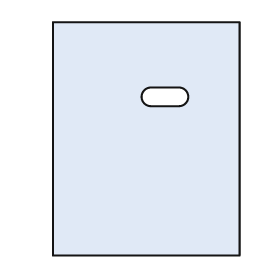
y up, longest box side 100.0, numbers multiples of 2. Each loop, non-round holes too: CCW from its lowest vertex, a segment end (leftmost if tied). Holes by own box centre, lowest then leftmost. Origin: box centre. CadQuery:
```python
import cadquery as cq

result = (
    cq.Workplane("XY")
    .moveTo(-40.0, -50.0)
    .lineTo(40.0, -50.0)
    .lineTo(40.0, 50.0)
    .lineTo(-40.0, 50.0)
    .close()
    .moveTo(2.0, 14.0)
    .lineTo(14.0, 14.0)
    .threePointArc((18.0, 18.0), (14.0, 22.0))
    .lineTo(2.0, 22.0)
    .threePointArc((-2.0, 18.0), (2.0, 14.0))
    .close()
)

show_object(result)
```